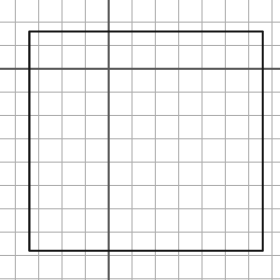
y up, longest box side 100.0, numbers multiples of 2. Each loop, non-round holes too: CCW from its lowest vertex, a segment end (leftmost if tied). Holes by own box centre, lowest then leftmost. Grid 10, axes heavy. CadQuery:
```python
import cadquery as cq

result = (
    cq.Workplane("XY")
    .moveTo(-34.0, -78.0)
    .lineTo(66.0, -78.0)
    .lineTo(66.0, 16.0)
    .lineTo(-34.0, 16.0)
    .close()
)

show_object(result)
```